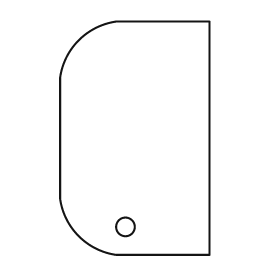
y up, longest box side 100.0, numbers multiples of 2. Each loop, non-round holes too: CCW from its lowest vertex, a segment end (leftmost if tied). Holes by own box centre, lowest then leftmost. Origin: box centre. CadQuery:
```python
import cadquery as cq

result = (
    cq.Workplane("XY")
    .moveTo(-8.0, -50.0)
    .lineTo(32.0, -50.0)
    .lineTo(32.0, 50.0)
    .lineTo(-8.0, 50.0)
    .threePointArc((-24.0, 42.0), (-32.0, 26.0))
    .lineTo(-32.0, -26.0)
    .threePointArc((-24.0, -42.0), (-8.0, -50.0))
    .close()
    .moveTo(-4.0, -38.0)
    .circle(4.0)
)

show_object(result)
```